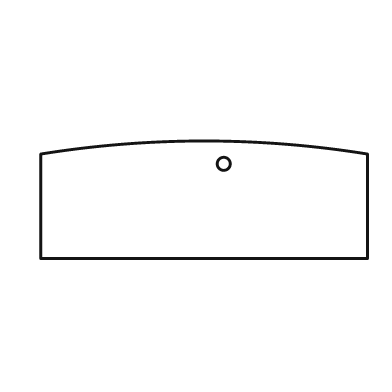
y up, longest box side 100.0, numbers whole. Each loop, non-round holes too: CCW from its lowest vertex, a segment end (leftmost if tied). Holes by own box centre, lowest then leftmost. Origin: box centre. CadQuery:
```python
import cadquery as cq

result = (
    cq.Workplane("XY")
    .moveTo(-50.0, -18.0)
    .lineTo(50.0, -18.0)
    .lineTo(50.0, 14.0)
    .threePointArc((0.0, 18.0), (-50.0, 14.0))
    .close()
    .moveTo(6.0, 11.0)
    .circle(2.0)
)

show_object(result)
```